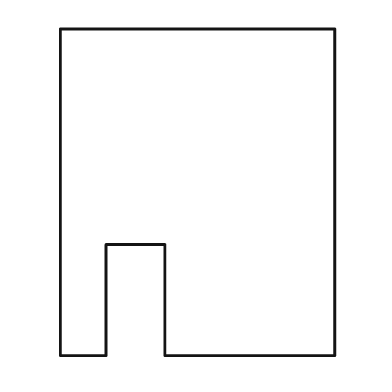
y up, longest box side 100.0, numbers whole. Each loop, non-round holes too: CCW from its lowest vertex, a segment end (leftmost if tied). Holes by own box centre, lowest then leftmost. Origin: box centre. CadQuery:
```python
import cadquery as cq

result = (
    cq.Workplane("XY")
    .moveTo(-42.0, -50.0)
    .lineTo(-28.0, -50.0)
    .lineTo(-28.0, -16.0)
    .lineTo(-10.0, -16.0)
    .lineTo(-10.0, -50.0)
    .lineTo(42.0, -50.0)
    .lineTo(42.0, 50.0)
    .lineTo(-42.0, 50.0)
    .close()
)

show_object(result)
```